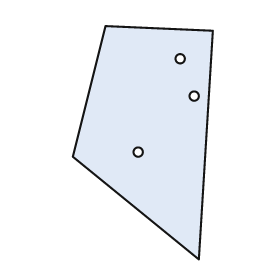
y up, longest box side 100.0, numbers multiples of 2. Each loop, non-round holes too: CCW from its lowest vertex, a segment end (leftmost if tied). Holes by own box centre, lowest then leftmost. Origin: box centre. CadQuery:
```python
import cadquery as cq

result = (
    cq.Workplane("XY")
    .moveTo(24.0, -50.0)
    .lineTo(30.0, 48.0)
    .lineTo(-16.0, 50.0)
    .lineTo(-30.0, -6.0)
    .close()
    .moveTo(-2.0, -4.0)
    .circle(2.0)
    .moveTo(22.0, 20.0)
    .circle(2.0)
    .moveTo(16.0, 36.0)
    .circle(2.0)
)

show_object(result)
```